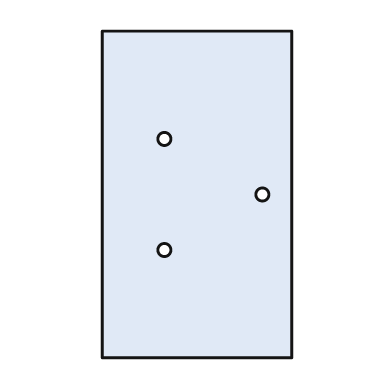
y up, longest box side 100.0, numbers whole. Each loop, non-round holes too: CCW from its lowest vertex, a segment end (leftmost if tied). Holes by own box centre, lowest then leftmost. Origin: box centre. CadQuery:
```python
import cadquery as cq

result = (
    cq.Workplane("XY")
    .moveTo(-29.0, -50.0)
    .lineTo(29.0, -50.0)
    .lineTo(29.0, 50.0)
    .lineTo(-29.0, 50.0)
    .close()
    .moveTo(-10.0, -17.0)
    .circle(2.0)
    .moveTo(20.0, 0.0)
    .circle(2.0)
    .moveTo(-10.0, 17.0)
    .circle(2.0)
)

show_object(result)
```